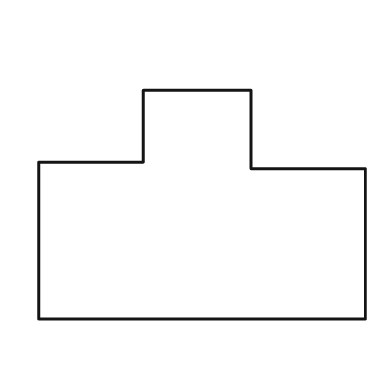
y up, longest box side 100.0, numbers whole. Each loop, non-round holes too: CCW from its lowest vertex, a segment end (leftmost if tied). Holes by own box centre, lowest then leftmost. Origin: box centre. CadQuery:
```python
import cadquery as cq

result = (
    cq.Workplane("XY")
    .moveTo(-50.0, -35.0)
    .lineTo(50.0, -35.0)
    .lineTo(50.0, 11.0)
    .lineTo(15.0, 11.0)
    .lineTo(15.0, 35.0)
    .lineTo(-18.0, 35.0)
    .lineTo(-18.0, 13.0)
    .lineTo(-50.0, 13.0)
    .close()
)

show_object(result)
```